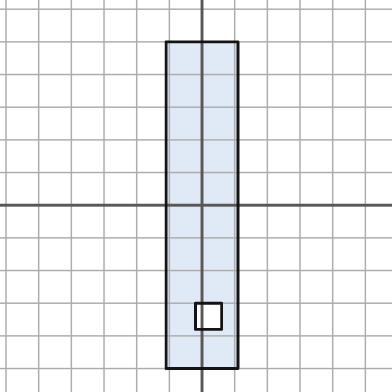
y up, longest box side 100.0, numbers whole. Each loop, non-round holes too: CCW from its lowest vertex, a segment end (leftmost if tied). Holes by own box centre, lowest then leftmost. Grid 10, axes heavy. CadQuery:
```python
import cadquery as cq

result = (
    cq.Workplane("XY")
    .moveTo(-11.0, -50.0)
    .lineTo(11.0, -50.0)
    .lineTo(11.0, 50.0)
    .lineTo(-11.0, 50.0)
    .close()
    .moveTo(-2.0, -38.0)
    .lineTo(6.0, -38.0)
    .lineTo(6.0, -30.0)
    .lineTo(-2.0, -30.0)
    .close()
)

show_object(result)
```